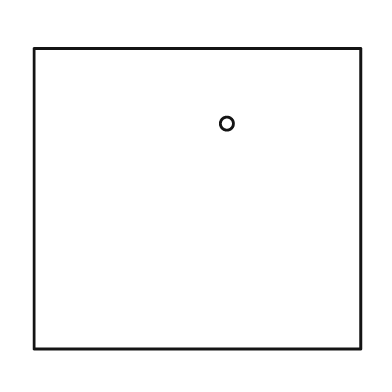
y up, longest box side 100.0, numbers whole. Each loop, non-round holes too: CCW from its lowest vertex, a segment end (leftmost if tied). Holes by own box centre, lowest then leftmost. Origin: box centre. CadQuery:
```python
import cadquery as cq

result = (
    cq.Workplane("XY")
    .moveTo(-50.0, -46.0)
    .lineTo(50.0, -46.0)
    .lineTo(50.0, 46.0)
    .lineTo(-50.0, 46.0)
    .close()
    .moveTo(9.0, 23.0)
    .circle(2.0)
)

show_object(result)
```